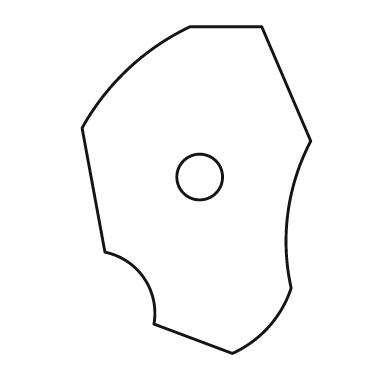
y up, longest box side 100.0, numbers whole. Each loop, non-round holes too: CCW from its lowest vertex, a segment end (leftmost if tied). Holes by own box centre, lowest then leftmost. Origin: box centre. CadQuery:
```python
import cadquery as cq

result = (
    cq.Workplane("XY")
    .moveTo(11.0, -50.0)
    .threePointArc((22.0, -42.0), (29.0, -30.0))
    .threePointArc((28.0, -7.0), (35.0, 15.0))
    .lineTo(20.0, 50.0)
    .lineTo(-2.0, 50.0)
    .threePointArc((-21.0, 37.0), (-35.0, 19.0))
    .lineTo(-28.0, -19.0)
    .threePointArc((-16.0, -27.0), (-13.0, -41.0))
    .close()
    .moveTo(1.0, 4.0)
    .circle(7.0)
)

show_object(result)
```